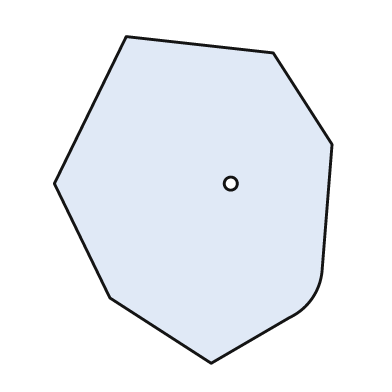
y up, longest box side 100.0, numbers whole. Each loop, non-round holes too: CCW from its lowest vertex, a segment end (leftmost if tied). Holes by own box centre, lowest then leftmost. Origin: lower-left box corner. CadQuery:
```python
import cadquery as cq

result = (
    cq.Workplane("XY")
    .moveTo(48.0, 0.0)
    .lineTo(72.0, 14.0)
    .threePointArc((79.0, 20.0), (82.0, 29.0))
    .lineTo(85.0, 67.0)
    .lineTo(67.0, 95.0)
    .lineTo(22.0, 100.0)
    .lineTo(0.0, 55.0)
    .lineTo(17.0, 20.0)
    .close()
    .moveTo(54.0, 55.0)
    .circle(2.0)
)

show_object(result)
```